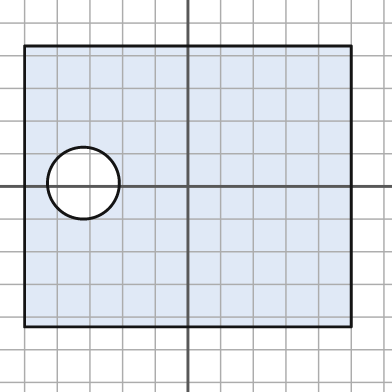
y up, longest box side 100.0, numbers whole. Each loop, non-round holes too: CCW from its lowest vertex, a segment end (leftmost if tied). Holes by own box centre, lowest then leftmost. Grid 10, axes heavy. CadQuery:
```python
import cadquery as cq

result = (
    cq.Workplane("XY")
    .moveTo(-50.0, -43.0)
    .lineTo(50.0, -43.0)
    .lineTo(50.0, 43.0)
    .lineTo(-50.0, 43.0)
    .close()
    .moveTo(-32.0, 1.0)
    .circle(11.0)
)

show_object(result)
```